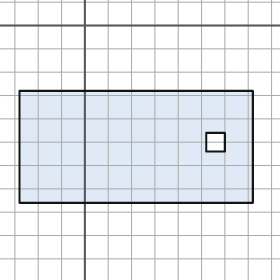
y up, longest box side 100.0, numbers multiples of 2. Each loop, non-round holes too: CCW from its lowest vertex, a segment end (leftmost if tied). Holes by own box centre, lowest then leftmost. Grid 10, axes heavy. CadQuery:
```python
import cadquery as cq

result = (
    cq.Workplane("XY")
    .moveTo(-28.0, -76.0)
    .lineTo(72.0, -76.0)
    .lineTo(72.0, -28.0)
    .lineTo(-28.0, -28.0)
    .close()
    .moveTo(52.0, -54.0)
    .lineTo(60.0, -54.0)
    .lineTo(60.0, -46.0)
    .lineTo(52.0, -46.0)
    .close()
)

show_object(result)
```